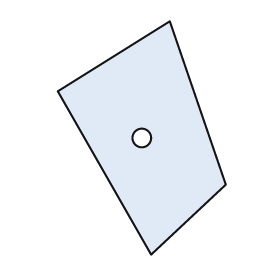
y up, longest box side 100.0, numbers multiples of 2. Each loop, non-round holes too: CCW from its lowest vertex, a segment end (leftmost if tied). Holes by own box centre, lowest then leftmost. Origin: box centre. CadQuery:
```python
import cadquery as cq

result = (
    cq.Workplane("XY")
    .moveTo(4.0, -50.0)
    .lineTo(36.0, -20.0)
    .lineTo(12.0, 50.0)
    .lineTo(-36.0, 20.0)
    .close()
    .moveTo(0.0, 0.0)
    .circle(4.0)
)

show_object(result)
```